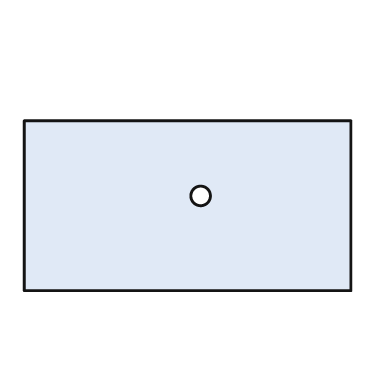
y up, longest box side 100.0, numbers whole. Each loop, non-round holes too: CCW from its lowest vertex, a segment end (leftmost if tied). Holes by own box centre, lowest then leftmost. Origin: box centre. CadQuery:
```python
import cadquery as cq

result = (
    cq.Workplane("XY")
    .moveTo(-50.0, -26.0)
    .lineTo(50.0, -26.0)
    .lineTo(50.0, 26.0)
    .lineTo(-50.0, 26.0)
    .close()
    .moveTo(4.0, 3.0)
    .circle(3.0)
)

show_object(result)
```